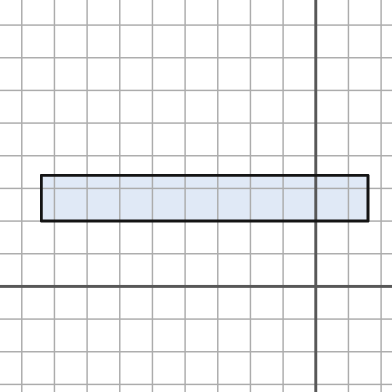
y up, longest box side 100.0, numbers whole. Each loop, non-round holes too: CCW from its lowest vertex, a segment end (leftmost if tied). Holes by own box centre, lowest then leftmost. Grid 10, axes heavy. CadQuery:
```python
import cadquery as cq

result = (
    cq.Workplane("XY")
    .moveTo(-84.0, 20.0)
    .lineTo(16.0, 20.0)
    .lineTo(16.0, 34.0)
    .lineTo(-84.0, 34.0)
    .close()
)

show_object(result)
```